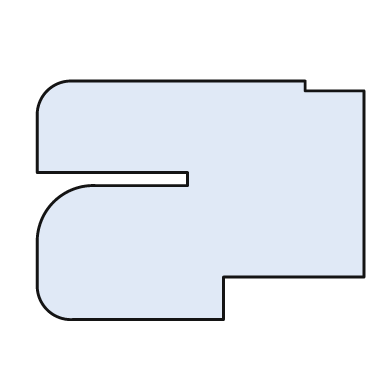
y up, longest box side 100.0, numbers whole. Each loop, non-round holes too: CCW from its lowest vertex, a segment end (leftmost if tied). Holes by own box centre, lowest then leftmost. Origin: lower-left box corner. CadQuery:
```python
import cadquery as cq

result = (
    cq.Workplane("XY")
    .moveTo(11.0, 0.0)
    .lineTo(57.0, 0.0)
    .lineTo(57.0, 13.0)
    .lineTo(100.0, 13.0)
    .lineTo(100.0, 70.0)
    .lineTo(82.0, 70.0)
    .lineTo(82.0, 73.0)
    .lineTo(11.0, 73.0)
    .threePointArc((3.0, 70.0), (0.0, 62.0))
    .lineTo(0.0, 45.0)
    .lineTo(46.0, 45.0)
    .lineTo(46.0, 41.0)
    .lineTo(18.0, 41.0)
    .threePointArc((5.0, 36.0), (0.0, 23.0))
    .lineTo(0.0, 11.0)
    .threePointArc((3.0, 3.0), (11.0, 0.0))
    .close()
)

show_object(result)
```